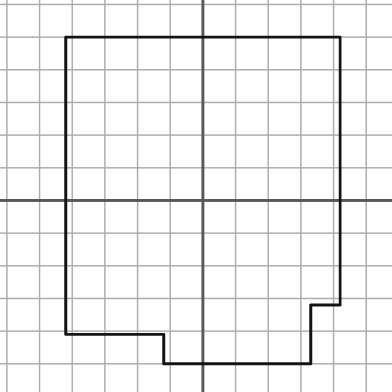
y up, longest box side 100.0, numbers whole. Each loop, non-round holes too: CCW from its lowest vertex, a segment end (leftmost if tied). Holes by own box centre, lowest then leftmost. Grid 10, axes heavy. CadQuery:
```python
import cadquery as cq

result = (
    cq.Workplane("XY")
    .moveTo(-12.0, -50.0)
    .lineTo(33.0, -50.0)
    .lineTo(33.0, -32.0)
    .lineTo(42.0, -32.0)
    .lineTo(42.0, 50.0)
    .lineTo(-42.0, 50.0)
    .lineTo(-42.0, -41.0)
    .lineTo(-12.0, -41.0)
    .close()
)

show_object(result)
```